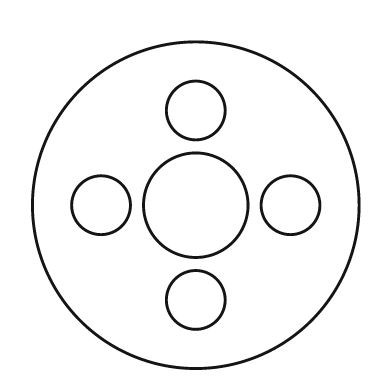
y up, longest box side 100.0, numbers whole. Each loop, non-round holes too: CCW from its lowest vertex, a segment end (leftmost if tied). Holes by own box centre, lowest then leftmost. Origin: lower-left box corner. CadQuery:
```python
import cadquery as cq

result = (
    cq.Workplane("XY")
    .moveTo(50.0, 50.0)
    .circle(50.0)
    .moveTo(50.0, 21.0)
    .circle(9.0)
    .moveTo(21.0, 50.0)
    .circle(9.0)
    .moveTo(50.0, 50.0)
    .circle(16.0)
    .moveTo(79.0, 50.0)
    .circle(9.0)
    .moveTo(50.0, 79.0)
    .circle(9.0)
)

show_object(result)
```